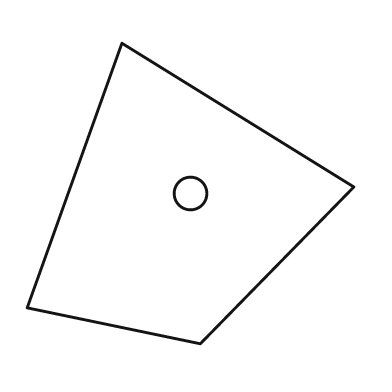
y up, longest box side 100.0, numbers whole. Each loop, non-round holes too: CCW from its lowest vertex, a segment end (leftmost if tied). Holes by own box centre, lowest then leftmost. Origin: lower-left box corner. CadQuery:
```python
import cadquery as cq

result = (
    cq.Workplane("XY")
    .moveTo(53.0, 0.0)
    .lineTo(100.0, 48.0)
    .lineTo(29.0, 92.0)
    .lineTo(0.0, 11.0)
    .close()
    .moveTo(50.0, 46.0)
    .circle(5.0)
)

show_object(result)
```